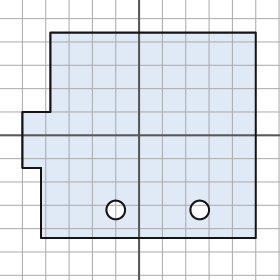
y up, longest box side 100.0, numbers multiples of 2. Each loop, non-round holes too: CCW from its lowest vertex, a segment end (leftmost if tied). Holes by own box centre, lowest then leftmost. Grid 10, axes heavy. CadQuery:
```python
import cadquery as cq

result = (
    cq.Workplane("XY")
    .moveTo(-42.0, -44.0)
    .lineTo(50.0, -44.0)
    .lineTo(50.0, 44.0)
    .lineTo(-38.0, 44.0)
    .lineTo(-38.0, 10.0)
    .lineTo(-50.0, 10.0)
    .lineTo(-50.0, -14.0)
    .lineTo(-42.0, -14.0)
    .close()
    .moveTo(-10.0, -32.0)
    .circle(4.0)
    .moveTo(26.0, -32.0)
    .circle(4.0)
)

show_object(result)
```